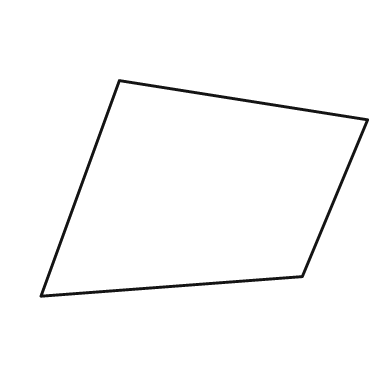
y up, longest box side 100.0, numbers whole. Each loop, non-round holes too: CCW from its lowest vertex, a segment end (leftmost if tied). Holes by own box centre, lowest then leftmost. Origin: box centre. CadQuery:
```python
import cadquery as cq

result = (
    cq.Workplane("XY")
    .moveTo(-50.0, -33.0)
    .lineTo(30.0, -27.0)
    .lineTo(50.0, 21.0)
    .lineTo(-26.0, 33.0)
    .close()
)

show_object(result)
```